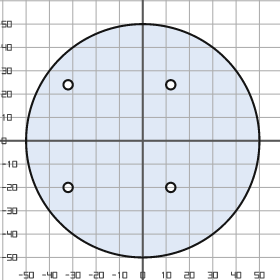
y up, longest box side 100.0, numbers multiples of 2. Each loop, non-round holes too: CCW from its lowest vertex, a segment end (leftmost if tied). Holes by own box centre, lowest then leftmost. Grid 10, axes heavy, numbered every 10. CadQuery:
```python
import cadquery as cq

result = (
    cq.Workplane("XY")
    .moveTo(0.0, 0.0)
    .circle(50.0)
    .moveTo(-32.0, -20.0)
    .circle(2.0)
    .moveTo(12.0, -20.0)
    .circle(2.0)
    .moveTo(-32.0, 24.0)
    .circle(2.0)
    .moveTo(12.0, 24.0)
    .circle(2.0)
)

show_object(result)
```